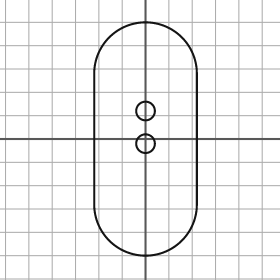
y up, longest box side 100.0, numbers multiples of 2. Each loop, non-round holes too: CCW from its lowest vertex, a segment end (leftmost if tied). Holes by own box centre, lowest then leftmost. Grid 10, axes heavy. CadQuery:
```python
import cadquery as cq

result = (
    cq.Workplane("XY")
    .moveTo(-22.0, -28.0)
    .threePointArc((0.0, -50.0), (22.0, -28.0))
    .lineTo(22.0, 28.0)
    .threePointArc((0.0, 50.0), (-22.0, 28.0))
    .close()
    .moveTo(0.0, -2.0)
    .circle(4.0)
    .moveTo(0.0, 12.0)
    .circle(4.0)
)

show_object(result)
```